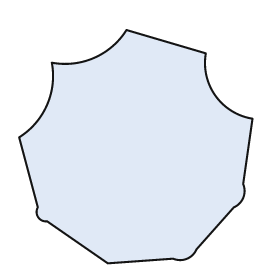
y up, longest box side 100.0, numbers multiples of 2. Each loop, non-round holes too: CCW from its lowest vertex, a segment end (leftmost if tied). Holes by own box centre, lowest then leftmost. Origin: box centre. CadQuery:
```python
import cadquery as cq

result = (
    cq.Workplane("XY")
    .moveTo(-12.0, -50.0)
    .lineTo(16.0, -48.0)
    .threePointArc((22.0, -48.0), (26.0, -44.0))
    .lineTo(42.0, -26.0)
    .threePointArc((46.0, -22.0), (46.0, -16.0))
    .lineTo(50.0, 12.0)
    .threePointArc((34.0, 22.0), (30.0, 40.0))
    .lineTo(-4.0, 50.0)
    .threePointArc((-18.0, 38.0), (-36.0, 36.0))
    .threePointArc((-38.0, 18.0), (-50.0, 4.0))
    .lineTo(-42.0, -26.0)
    .threePointArc((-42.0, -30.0), (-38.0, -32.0))
    .close()
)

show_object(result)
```